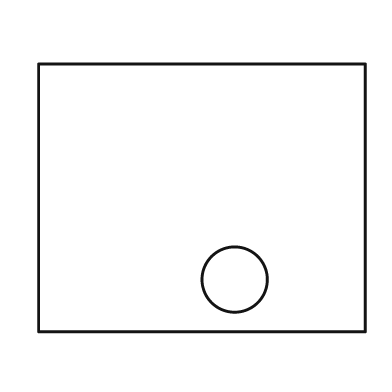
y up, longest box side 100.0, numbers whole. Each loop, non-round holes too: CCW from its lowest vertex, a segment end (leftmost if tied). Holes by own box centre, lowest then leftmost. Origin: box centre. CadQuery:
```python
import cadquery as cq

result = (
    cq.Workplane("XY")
    .moveTo(-50.0, -41.0)
    .lineTo(50.0, -41.0)
    .lineTo(50.0, 41.0)
    .lineTo(-50.0, 41.0)
    .close()
    .moveTo(10.0, -25.0)
    .circle(10.0)
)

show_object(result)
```